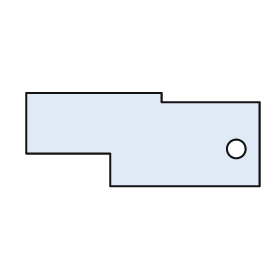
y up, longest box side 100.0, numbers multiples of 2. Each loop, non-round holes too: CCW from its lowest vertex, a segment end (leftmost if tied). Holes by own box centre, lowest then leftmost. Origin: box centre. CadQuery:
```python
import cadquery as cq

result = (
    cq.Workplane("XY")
    .moveTo(-14.0, -20.0)
    .lineTo(50.0, -20.0)
    .lineTo(50.0, 16.0)
    .lineTo(8.0, 16.0)
    .lineTo(8.0, 20.0)
    .lineTo(-50.0, 20.0)
    .lineTo(-50.0, -6.0)
    .lineTo(-14.0, -6.0)
    .close()
    .moveTo(40.0, -4.0)
    .circle(4.0)
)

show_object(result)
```